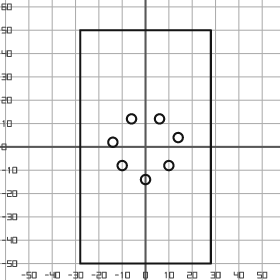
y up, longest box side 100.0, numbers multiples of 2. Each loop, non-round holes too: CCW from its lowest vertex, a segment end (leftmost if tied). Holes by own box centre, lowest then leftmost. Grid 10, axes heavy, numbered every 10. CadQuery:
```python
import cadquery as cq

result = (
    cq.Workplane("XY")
    .moveTo(-28.0, -50.0)
    .lineTo(28.0, -50.0)
    .lineTo(28.0, 50.0)
    .lineTo(-28.0, 50.0)
    .close()
    .moveTo(0.0, -14.0)
    .circle(2.0)
    .moveTo(-10.0, -8.0)
    .circle(2.0)
    .moveTo(10.0, -8.0)
    .circle(2.0)
    .moveTo(-14.0, 2.0)
    .circle(2.0)
    .moveTo(14.0, 4.0)
    .circle(2.0)
    .moveTo(-6.0, 12.0)
    .circle(2.0)
    .moveTo(6.0, 12.0)
    .circle(2.0)
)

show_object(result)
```